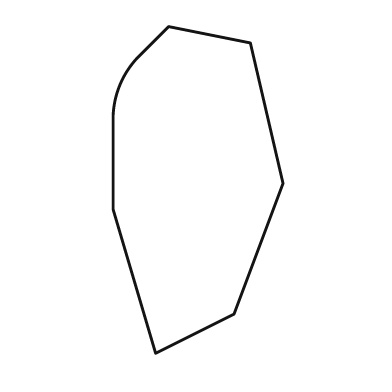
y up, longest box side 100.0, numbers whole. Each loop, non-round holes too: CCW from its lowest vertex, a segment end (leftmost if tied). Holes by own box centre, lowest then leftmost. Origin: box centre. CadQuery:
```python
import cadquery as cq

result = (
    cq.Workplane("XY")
    .moveTo(-13.0, -50.0)
    .lineTo(11.0, -38.0)
    .lineTo(26.0, 2.0)
    .lineTo(16.0, 45.0)
    .lineTo(-9.0, 50.0)
    .lineTo(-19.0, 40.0)
    .threePointArc((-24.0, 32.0), (-26.0, 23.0))
    .lineTo(-26.0, -6.0)
    .close()
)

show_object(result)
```